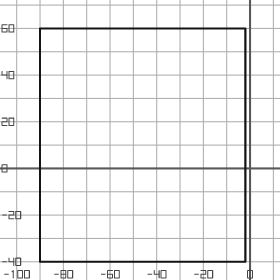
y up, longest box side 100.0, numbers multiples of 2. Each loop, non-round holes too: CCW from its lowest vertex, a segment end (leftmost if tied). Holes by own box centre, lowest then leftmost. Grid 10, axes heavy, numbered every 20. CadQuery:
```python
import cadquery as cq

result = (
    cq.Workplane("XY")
    .moveTo(-90.0, -40.0)
    .lineTo(-2.0, -40.0)
    .lineTo(-2.0, 60.0)
    .lineTo(-90.0, 60.0)
    .close()
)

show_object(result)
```